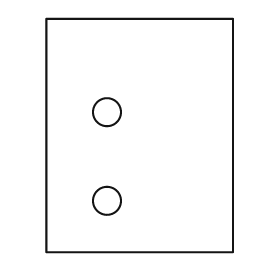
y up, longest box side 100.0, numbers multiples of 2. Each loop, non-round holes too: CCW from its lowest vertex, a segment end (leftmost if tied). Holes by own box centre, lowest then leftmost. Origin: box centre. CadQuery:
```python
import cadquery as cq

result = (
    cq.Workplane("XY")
    .moveTo(-40.0, -50.0)
    .lineTo(40.0, -50.0)
    .lineTo(40.0, 50.0)
    .lineTo(-40.0, 50.0)
    .close()
    .moveTo(-14.0, -28.0)
    .circle(6.0)
    .moveTo(-14.0, 10.0)
    .circle(6.0)
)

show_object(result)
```